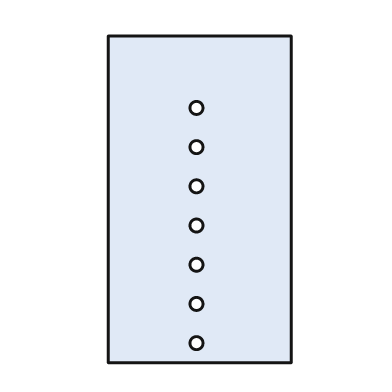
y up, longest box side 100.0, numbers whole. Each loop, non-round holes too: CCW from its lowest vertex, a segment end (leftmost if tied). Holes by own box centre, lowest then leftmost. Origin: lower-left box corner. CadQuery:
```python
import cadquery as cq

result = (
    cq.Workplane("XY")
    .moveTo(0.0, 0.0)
    .lineTo(56.0, 0.0)
    .lineTo(56.0, 100.0)
    .lineTo(0.0, 100.0)
    .close()
    .moveTo(27.0, 6.0)
    .circle(2.0)
    .moveTo(27.0, 18.0)
    .circle(2.0)
    .moveTo(27.0, 30.0)
    .circle(2.0)
    .moveTo(27.0, 42.0)
    .circle(2.0)
    .moveTo(27.0, 54.0)
    .circle(2.0)
    .moveTo(27.0, 66.0)
    .circle(2.0)
    .moveTo(27.0, 78.0)
    .circle(2.0)
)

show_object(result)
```